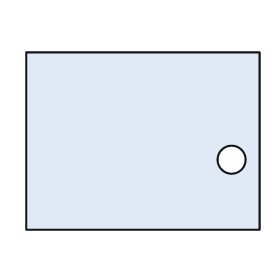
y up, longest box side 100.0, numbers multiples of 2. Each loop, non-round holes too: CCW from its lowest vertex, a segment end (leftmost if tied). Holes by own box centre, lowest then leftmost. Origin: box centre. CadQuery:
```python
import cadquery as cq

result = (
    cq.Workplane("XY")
    .moveTo(-50.0, -38.0)
    .lineTo(50.0, -38.0)
    .lineTo(50.0, 38.0)
    .lineTo(-50.0, 38.0)
    .close()
    .moveTo(38.0, -8.0)
    .circle(6.0)
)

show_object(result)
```